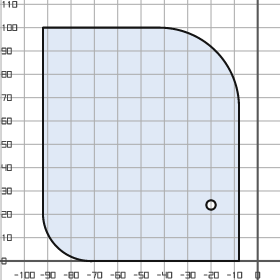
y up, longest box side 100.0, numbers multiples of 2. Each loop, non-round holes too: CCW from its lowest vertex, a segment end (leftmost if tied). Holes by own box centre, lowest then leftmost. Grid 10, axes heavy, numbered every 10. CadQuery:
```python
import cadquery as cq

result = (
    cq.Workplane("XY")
    .moveTo(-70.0, 0.0)
    .lineTo(-8.0, 0.0)
    .lineTo(-8.0, 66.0)
    .threePointArc((-18.0, 90.0), (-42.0, 100.0))
    .lineTo(-92.0, 100.0)
    .lineTo(-92.0, 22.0)
    .threePointArc((-86.0, 6.0), (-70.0, 0.0))
    .close()
    .moveTo(-20.0, 24.0)
    .circle(2.0)
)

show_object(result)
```